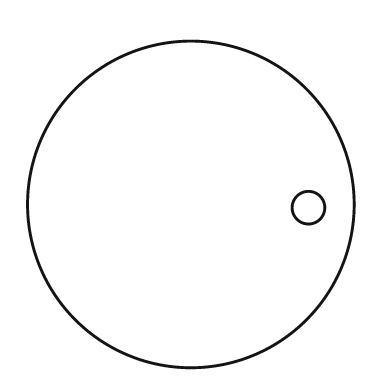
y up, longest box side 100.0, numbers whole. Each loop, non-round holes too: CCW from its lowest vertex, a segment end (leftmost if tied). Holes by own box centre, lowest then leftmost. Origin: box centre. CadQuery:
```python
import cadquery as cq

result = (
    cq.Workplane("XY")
    .moveTo(0.0, 0.0)
    .circle(50.0)
    .moveTo(36.0, -1.0)
    .circle(5.0)
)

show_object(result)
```